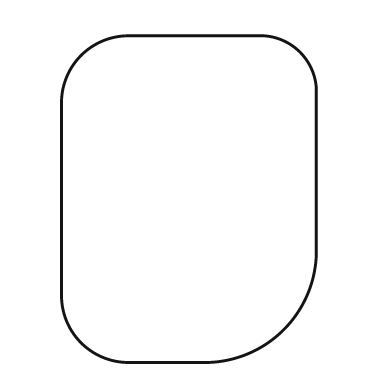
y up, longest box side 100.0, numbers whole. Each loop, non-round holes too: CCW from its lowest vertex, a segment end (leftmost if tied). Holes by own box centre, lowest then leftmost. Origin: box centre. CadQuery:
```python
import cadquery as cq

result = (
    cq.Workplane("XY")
    .moveTo(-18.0, -50.0)
    .lineTo(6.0, -50.0)
    .threePointArc((29.0, -40.0), (39.0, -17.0))
    .lineTo(39.0, 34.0)
    .threePointArc((34.0, 45.0), (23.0, 50.0))
    .lineTo(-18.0, 50.0)
    .threePointArc((-33.0, 44.0), (-39.0, 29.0))
    .lineTo(-39.0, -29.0)
    .threePointArc((-33.0, -44.0), (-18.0, -50.0))
    .close()
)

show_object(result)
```